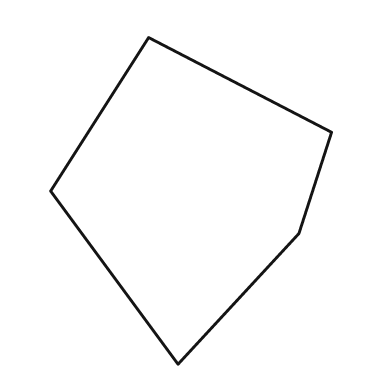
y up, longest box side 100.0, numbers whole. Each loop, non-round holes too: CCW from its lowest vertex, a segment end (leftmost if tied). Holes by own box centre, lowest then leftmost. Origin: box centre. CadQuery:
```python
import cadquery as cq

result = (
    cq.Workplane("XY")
    .moveTo(-4.0, -50.0)
    .lineTo(33.0, -10.0)
    .lineTo(43.0, 21.0)
    .lineTo(-13.0, 50.0)
    .lineTo(-43.0, 3.0)
    .close()
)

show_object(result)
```